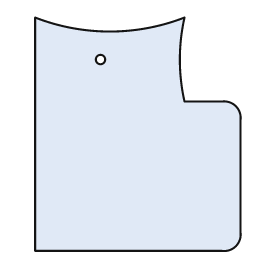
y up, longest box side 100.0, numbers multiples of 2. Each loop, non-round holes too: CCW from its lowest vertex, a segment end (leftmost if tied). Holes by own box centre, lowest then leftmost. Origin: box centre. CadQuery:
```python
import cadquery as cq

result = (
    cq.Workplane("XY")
    .moveTo(-44.0, -50.0)
    .lineTo(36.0, -50.0)
    .threePointArc((42.0, -48.0), (44.0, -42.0))
    .lineTo(44.0, 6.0)
    .threePointArc((42.0, 12.0), (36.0, 14.0))
    .lineTo(20.0, 14.0)
    .threePointArc((18.0, 32.0), (20.0, 50.0))
    .threePointArc((-12.0, 44.0), (-44.0, 50.0))
    .close()
    .moveTo(-16.0, 32.0)
    .circle(2.0)
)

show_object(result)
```